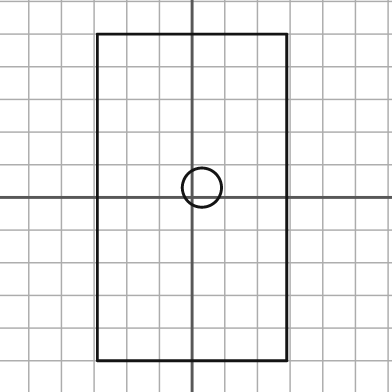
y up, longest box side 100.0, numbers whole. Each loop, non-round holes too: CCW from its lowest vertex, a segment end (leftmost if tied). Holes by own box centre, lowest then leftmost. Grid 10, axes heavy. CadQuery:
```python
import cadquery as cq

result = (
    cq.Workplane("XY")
    .moveTo(-29.0, -50.0)
    .lineTo(29.0, -50.0)
    .lineTo(29.0, 50.0)
    .lineTo(-29.0, 50.0)
    .close()
    .moveTo(3.0, 3.0)
    .circle(6.0)
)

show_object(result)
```